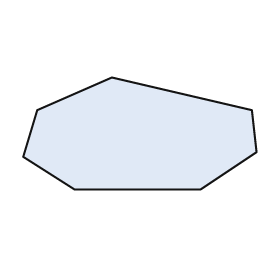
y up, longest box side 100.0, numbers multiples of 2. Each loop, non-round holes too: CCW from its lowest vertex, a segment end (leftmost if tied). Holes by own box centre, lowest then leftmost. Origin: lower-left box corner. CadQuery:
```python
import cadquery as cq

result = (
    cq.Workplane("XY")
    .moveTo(22.0, 0.0)
    .lineTo(76.0, 0.0)
    .lineTo(100.0, 16.0)
    .lineTo(98.0, 34.0)
    .lineTo(38.0, 48.0)
    .lineTo(6.0, 34.0)
    .lineTo(0.0, 14.0)
    .close()
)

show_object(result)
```